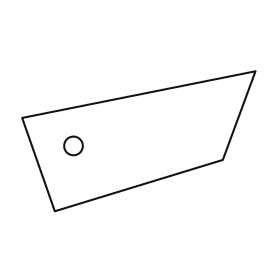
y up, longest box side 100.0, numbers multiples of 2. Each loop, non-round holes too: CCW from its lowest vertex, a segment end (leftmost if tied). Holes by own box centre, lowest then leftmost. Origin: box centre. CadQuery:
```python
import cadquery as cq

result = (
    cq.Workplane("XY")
    .moveTo(-36.0, -30.0)
    .lineTo(36.0, -8.0)
    .lineTo(50.0, 30.0)
    .lineTo(-50.0, 10.0)
    .close()
    .moveTo(-28.0, -2.0)
    .circle(4.0)
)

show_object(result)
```